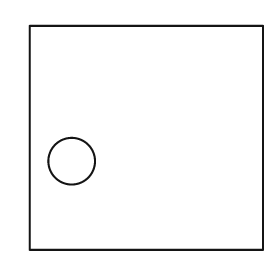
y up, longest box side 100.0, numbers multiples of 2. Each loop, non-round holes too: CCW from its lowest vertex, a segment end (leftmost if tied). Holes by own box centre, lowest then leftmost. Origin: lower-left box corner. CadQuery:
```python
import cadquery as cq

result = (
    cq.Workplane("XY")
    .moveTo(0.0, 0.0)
    .lineTo(100.0, 0.0)
    .lineTo(100.0, 96.0)
    .lineTo(0.0, 96.0)
    .close()
    .moveTo(18.0, 38.0)
    .circle(10.0)
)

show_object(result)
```